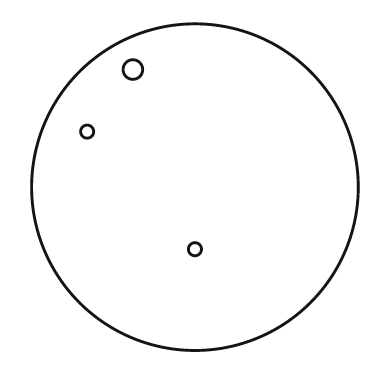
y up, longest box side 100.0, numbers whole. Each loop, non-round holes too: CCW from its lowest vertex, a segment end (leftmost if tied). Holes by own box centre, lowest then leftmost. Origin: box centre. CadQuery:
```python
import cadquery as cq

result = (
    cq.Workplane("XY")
    .moveTo(0.0, 0.0)
    .circle(50.0)
    .moveTo(0.0, -19.0)
    .circle(2.0)
    .moveTo(-33.0, 17.0)
    .circle(2.0)
    .moveTo(-19.0, 36.0)
    .circle(3.0)
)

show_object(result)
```